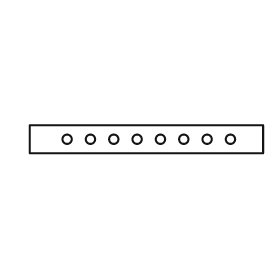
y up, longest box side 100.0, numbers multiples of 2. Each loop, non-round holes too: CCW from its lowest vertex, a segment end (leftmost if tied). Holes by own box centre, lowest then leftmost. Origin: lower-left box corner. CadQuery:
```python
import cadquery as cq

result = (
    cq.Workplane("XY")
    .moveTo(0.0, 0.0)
    .lineTo(100.0, 0.0)
    .lineTo(100.0, 12.0)
    .lineTo(0.0, 12.0)
    .close()
    .moveTo(16.0, 6.0)
    .circle(2.0)
    .moveTo(26.0, 6.0)
    .circle(2.0)
    .moveTo(36.0, 6.0)
    .circle(2.0)
    .moveTo(46.0, 6.0)
    .circle(2.0)
    .moveTo(56.0, 6.0)
    .circle(2.0)
    .moveTo(66.0, 6.0)
    .circle(2.0)
    .moveTo(76.0, 6.0)
    .circle(2.0)
    .moveTo(86.0, 6.0)
    .circle(2.0)
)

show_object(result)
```